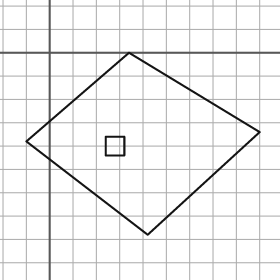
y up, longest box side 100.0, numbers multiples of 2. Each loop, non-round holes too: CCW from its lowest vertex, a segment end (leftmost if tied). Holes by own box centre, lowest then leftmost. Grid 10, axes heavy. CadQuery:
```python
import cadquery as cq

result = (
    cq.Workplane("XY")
    .moveTo(42.0, -78.0)
    .lineTo(90.0, -34.0)
    .lineTo(34.0, 0.0)
    .lineTo(-10.0, -38.0)
    .close()
    .moveTo(24.0, -44.0)
    .lineTo(32.0, -44.0)
    .lineTo(32.0, -36.0)
    .lineTo(24.0, -36.0)
    .close()
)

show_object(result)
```